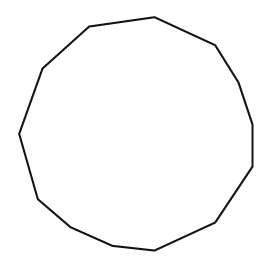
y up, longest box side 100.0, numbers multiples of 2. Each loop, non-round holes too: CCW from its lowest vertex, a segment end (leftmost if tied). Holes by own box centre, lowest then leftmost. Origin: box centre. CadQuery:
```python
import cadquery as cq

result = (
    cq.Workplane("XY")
    .moveTo(8.0, -50.0)
    .lineTo(34.0, -38.0)
    .lineTo(50.0, -14.0)
    .lineTo(50.0, 4.0)
    .lineTo(44.0, 22.0)
    .lineTo(34.0, 38.0)
    .lineTo(8.0, 50.0)
    .lineTo(-20.0, 46.0)
    .lineTo(-40.0, 28.0)
    .lineTo(-50.0, 0.0)
    .lineTo(-42.0, -28.0)
    .lineTo(-28.0, -40.0)
    .lineTo(-10.0, -48.0)
    .close()
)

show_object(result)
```